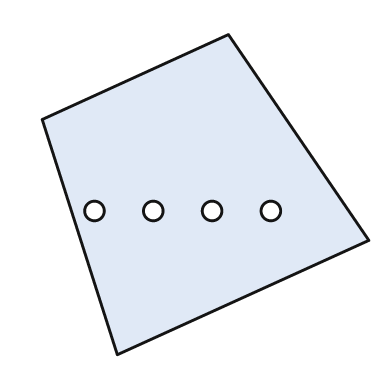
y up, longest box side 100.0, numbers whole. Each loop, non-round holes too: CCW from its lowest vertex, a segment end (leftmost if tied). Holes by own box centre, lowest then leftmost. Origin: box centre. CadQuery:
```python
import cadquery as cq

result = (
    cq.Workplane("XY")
    .moveTo(-27.0, -49.0)
    .lineTo(50.0, -14.0)
    .lineTo(7.0, 49.0)
    .lineTo(-50.0, 23.0)
    .close()
    .moveTo(-34.0, -5.0)
    .circle(3.0)
    .moveTo(-16.0, -5.0)
    .circle(3.0)
    .moveTo(2.0, -5.0)
    .circle(3.0)
    .moveTo(20.0, -5.0)
    .circle(3.0)
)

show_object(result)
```